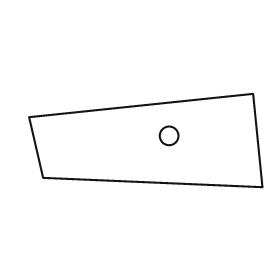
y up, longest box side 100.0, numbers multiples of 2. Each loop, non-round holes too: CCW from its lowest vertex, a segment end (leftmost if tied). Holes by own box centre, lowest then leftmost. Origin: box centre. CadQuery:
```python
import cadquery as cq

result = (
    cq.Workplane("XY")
    .moveTo(50.0, -20.0)
    .lineTo(46.0, 20.0)
    .lineTo(-50.0, 10.0)
    .lineTo(-44.0, -16.0)
    .close()
    .moveTo(10.0, 2.0)
    .circle(4.0)
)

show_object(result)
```